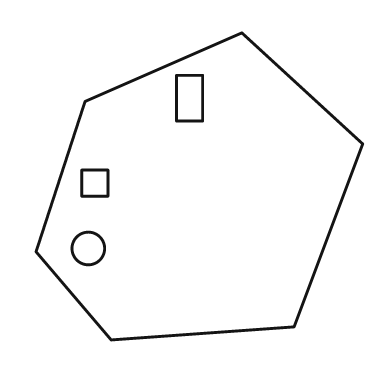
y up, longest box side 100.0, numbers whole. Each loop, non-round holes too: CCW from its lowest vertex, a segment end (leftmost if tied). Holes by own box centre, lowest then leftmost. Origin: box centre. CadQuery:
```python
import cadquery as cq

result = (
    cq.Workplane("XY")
    .moveTo(-27.0, -47.0)
    .lineTo(29.0, -43.0)
    .lineTo(50.0, 13.0)
    .lineTo(13.0, 47.0)
    .lineTo(-35.0, 26.0)
    .lineTo(-50.0, -20.0)
    .close()
    .moveTo(-34.0, -19.0)
    .circle(5.0)
    .moveTo(-36.0, -3.0)
    .lineTo(-28.0, -3.0)
    .lineTo(-28.0, 5.0)
    .lineTo(-36.0, 5.0)
    .close()
    .moveTo(-7.0, 20.0)
    .lineTo(1.0, 20.0)
    .lineTo(1.0, 34.0)
    .lineTo(-7.0, 34.0)
    .close()
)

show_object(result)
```